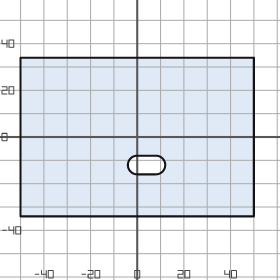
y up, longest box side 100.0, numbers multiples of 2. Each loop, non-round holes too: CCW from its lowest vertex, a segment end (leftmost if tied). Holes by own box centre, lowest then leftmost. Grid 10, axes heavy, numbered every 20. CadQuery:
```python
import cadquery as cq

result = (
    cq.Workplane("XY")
    .moveTo(-50.0, -34.0)
    .lineTo(50.0, -34.0)
    .lineTo(50.0, 34.0)
    .lineTo(-50.0, 34.0)
    .close()
    .moveTo(0.0, -16.0)
    .lineTo(8.0, -16.0)
    .threePointArc((12.0, -12.0), (8.0, -8.0))
    .lineTo(0.0, -8.0)
    .threePointArc((-4.0, -12.0), (0.0, -16.0))
    .close()
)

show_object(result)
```